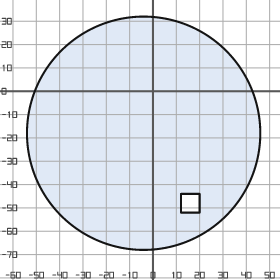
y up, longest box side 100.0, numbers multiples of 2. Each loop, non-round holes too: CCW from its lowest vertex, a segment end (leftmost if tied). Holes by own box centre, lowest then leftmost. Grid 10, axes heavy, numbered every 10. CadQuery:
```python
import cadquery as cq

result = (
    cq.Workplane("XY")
    .moveTo(-4.0, -18.0)
    .circle(50.0)
    .moveTo(12.0, -52.0)
    .lineTo(20.0, -52.0)
    .lineTo(20.0, -44.0)
    .lineTo(12.0, -44.0)
    .close()
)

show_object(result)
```